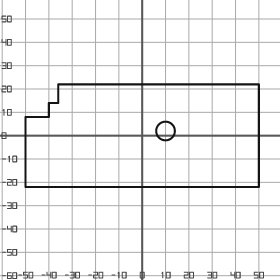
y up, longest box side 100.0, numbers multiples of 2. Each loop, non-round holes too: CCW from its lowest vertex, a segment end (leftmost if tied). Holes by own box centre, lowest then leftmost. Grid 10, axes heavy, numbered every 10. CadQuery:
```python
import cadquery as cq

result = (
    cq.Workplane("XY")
    .moveTo(-50.0, -22.0)
    .lineTo(50.0, -22.0)
    .lineTo(50.0, 22.0)
    .lineTo(-36.0, 22.0)
    .lineTo(-36.0, 14.0)
    .lineTo(-40.0, 14.0)
    .lineTo(-40.0, 8.0)
    .lineTo(-50.0, 8.0)
    .close()
    .moveTo(10.0, 2.0)
    .circle(4.0)
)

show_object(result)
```